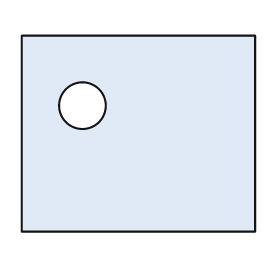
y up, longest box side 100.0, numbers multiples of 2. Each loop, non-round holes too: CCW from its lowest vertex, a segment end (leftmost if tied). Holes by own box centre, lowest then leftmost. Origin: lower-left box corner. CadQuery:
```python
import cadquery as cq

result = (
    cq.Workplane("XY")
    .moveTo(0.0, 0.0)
    .lineTo(100.0, 0.0)
    .lineTo(100.0, 84.0)
    .lineTo(0.0, 84.0)
    .close()
    .moveTo(26.0, 54.0)
    .circle(10.0)
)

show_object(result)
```